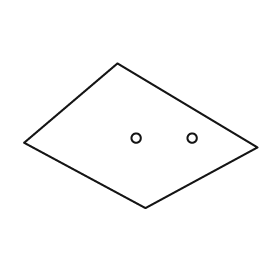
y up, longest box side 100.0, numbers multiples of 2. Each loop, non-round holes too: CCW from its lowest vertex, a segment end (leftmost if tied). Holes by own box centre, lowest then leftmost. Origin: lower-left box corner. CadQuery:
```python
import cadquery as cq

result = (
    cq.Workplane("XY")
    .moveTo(52.0, 0.0)
    .lineTo(100.0, 26.0)
    .lineTo(40.0, 62.0)
    .lineTo(0.0, 28.0)
    .close()
    .moveTo(48.0, 30.0)
    .circle(2.0)
    .moveTo(72.0, 30.0)
    .circle(2.0)
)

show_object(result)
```